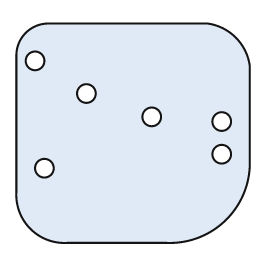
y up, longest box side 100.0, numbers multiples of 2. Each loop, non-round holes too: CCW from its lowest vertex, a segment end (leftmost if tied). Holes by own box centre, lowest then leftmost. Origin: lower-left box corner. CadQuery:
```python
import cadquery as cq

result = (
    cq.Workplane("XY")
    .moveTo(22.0, 0.0)
    .lineTo(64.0, 0.0)
    .threePointArc((90.0, 10.0), (100.0, 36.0))
    .lineTo(100.0, 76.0)
    .threePointArc((94.0, 88.0), (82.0, 94.0))
    .lineTo(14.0, 94.0)
    .threePointArc((4.0, 90.0), (0.0, 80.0))
    .lineTo(0.0, 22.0)
    .threePointArc((6.0, 6.0), (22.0, 0.0))
    .close()
    .moveTo(12.0, 32.0)
    .circle(4.0)
    .moveTo(88.0, 38.0)
    .circle(4.0)
    .moveTo(88.0, 52.0)
    .circle(4.0)
    .moveTo(58.0, 54.0)
    .circle(4.0)
    .moveTo(30.0, 64.0)
    .circle(4.0)
    .moveTo(8.0, 78.0)
    .circle(4.0)
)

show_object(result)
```